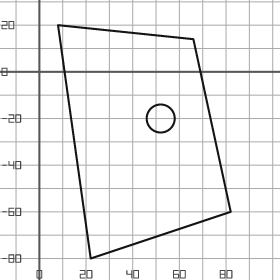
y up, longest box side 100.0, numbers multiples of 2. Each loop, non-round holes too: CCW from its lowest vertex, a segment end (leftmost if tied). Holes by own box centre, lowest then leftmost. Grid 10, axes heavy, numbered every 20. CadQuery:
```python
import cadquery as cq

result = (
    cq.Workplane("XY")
    .moveTo(22.0, -80.0)
    .lineTo(82.0, -60.0)
    .lineTo(66.0, 14.0)
    .lineTo(8.0, 20.0)
    .close()
    .moveTo(52.0, -20.0)
    .circle(6.0)
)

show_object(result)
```